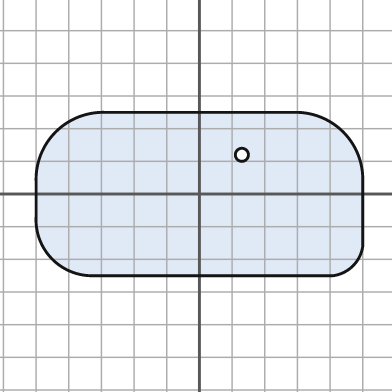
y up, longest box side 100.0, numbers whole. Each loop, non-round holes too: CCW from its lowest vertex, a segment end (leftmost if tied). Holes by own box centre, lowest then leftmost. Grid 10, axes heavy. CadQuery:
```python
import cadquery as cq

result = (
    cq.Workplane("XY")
    .moveTo(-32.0, -25.0)
    .lineTo(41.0, -25.0)
    .threePointArc((47.0, -22.0), (50.0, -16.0))
    .lineTo(50.0, 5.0)
    .threePointArc((44.0, 19.0), (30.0, 25.0))
    .lineTo(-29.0, 25.0)
    .threePointArc((-44.0, 19.0), (-50.0, 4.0))
    .lineTo(-50.0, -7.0)
    .threePointArc((-45.0, -20.0), (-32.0, -25.0))
    .close()
    .moveTo(13.0, 12.0)
    .circle(2.0)
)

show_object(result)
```